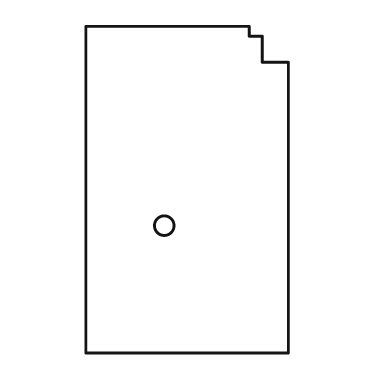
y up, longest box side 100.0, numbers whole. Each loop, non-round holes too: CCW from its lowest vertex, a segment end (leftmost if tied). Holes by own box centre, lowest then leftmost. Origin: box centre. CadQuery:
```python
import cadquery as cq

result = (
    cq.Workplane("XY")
    .moveTo(-31.0, -50.0)
    .lineTo(31.0, -50.0)
    .lineTo(31.0, 39.0)
    .lineTo(23.0, 39.0)
    .lineTo(23.0, 47.0)
    .lineTo(19.0, 47.0)
    .lineTo(19.0, 50.0)
    .lineTo(-31.0, 50.0)
    .close()
    .moveTo(-7.0, -11.0)
    .circle(3.0)
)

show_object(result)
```